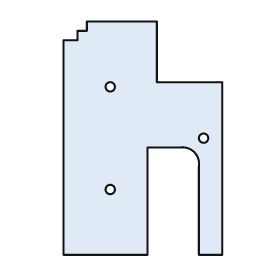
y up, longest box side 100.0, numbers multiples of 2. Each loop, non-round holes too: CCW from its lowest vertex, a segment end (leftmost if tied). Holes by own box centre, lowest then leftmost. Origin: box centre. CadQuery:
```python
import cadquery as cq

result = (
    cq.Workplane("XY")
    .moveTo(-34.0, -50.0)
    .lineTo(2.0, -50.0)
    .lineTo(2.0, -4.0)
    .lineTo(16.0, -4.0)
    .threePointArc((22.0, -6.0), (24.0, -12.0))
    .lineTo(24.0, -50.0)
    .lineTo(34.0, -50.0)
    .lineTo(34.0, 24.0)
    .lineTo(6.0, 24.0)
    .lineTo(6.0, 50.0)
    .lineTo(-24.0, 50.0)
    .lineTo(-24.0, 46.0)
    .lineTo(-28.0, 46.0)
    .lineTo(-28.0, 42.0)
    .lineTo(-34.0, 42.0)
    .close()
    .moveTo(-14.0, -22.0)
    .circle(2.0)
    .moveTo(26.0, 0.0)
    .circle(2.0)
    .moveTo(-14.0, 22.0)
    .circle(2.0)
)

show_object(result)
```